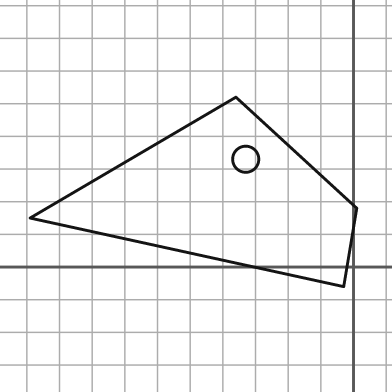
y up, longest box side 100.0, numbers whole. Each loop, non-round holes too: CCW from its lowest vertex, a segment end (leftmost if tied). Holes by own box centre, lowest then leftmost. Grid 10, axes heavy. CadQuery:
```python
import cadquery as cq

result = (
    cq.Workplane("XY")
    .moveTo(-3.0, -6.0)
    .lineTo(1.0, 18.0)
    .lineTo(-36.0, 52.0)
    .lineTo(-99.0, 15.0)
    .close()
    .moveTo(-33.0, 33.0)
    .circle(4.0)
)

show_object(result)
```